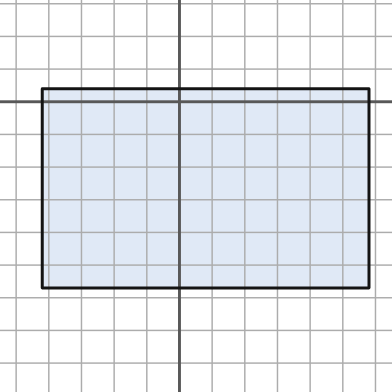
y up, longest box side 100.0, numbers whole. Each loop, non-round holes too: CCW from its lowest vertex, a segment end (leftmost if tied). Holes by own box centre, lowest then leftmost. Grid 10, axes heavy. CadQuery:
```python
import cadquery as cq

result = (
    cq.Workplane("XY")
    .moveTo(-42.0, -57.0)
    .lineTo(58.0, -57.0)
    .lineTo(58.0, 4.0)
    .lineTo(-42.0, 4.0)
    .close()
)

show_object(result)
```